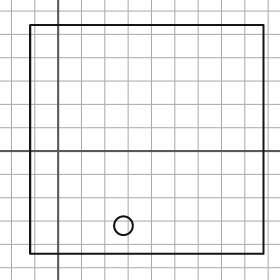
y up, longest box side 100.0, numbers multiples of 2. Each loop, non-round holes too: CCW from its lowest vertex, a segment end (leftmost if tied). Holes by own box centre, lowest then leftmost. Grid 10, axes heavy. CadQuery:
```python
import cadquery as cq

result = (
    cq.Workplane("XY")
    .moveTo(-12.0, -44.0)
    .lineTo(88.0, -44.0)
    .lineTo(88.0, 54.0)
    .lineTo(-12.0, 54.0)
    .close()
    .moveTo(28.0, -32.0)
    .circle(4.0)
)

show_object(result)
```